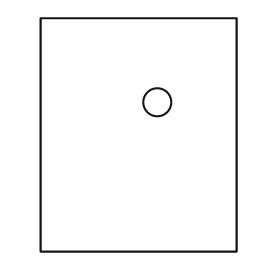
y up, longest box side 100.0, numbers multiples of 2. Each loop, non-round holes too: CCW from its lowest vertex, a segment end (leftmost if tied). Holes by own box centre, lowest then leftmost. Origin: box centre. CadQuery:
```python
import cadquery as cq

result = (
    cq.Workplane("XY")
    .moveTo(-42.0, -50.0)
    .lineTo(42.0, -50.0)
    .lineTo(42.0, 50.0)
    .lineTo(-42.0, 50.0)
    .close()
    .moveTo(8.0, 14.0)
    .circle(6.0)
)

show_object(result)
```